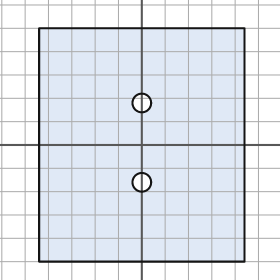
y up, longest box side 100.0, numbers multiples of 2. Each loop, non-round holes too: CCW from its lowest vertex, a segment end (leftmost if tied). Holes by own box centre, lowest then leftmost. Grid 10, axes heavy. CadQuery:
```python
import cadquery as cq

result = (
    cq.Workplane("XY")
    .moveTo(-44.0, -50.0)
    .lineTo(44.0, -50.0)
    .lineTo(44.0, 50.0)
    .lineTo(-44.0, 50.0)
    .close()
    .moveTo(0.0, -16.0)
    .circle(4.0)
    .moveTo(0.0, 18.0)
    .circle(4.0)
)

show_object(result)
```